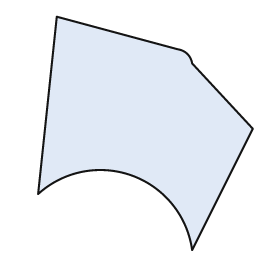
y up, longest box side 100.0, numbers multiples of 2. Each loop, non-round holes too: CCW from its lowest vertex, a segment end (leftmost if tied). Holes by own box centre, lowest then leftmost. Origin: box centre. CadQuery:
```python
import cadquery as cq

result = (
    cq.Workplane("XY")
    .moveTo(20.0, -50.0)
    .lineTo(46.0, 2.0)
    .lineTo(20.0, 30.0)
    .threePointArc((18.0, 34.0), (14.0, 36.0))
    .lineTo(-38.0, 50.0)
    .lineTo(-46.0, -26.0)
    .threePointArc((-6.0, -18.0), (20.0, -50.0))
    .close()
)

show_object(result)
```